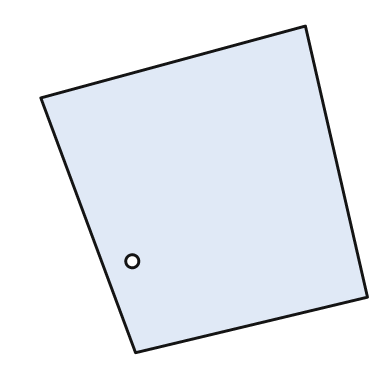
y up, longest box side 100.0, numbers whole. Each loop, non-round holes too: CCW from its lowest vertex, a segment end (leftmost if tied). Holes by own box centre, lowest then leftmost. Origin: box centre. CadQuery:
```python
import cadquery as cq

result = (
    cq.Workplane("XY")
    .moveTo(-21.0, -50.0)
    .lineTo(50.0, -33.0)
    .lineTo(31.0, 50.0)
    .lineTo(-50.0, 28.0)
    .close()
    .moveTo(-22.0, -22.0)
    .circle(2.0)
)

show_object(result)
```